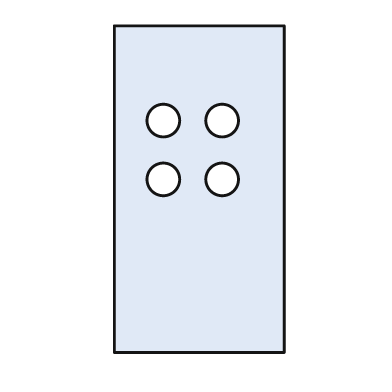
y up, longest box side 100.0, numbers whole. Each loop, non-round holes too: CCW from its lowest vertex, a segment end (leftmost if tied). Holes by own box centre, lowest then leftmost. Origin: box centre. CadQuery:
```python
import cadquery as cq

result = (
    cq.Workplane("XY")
    .moveTo(-26.0, -50.0)
    .lineTo(26.0, -50.0)
    .lineTo(26.0, 50.0)
    .lineTo(-26.0, 50.0)
    .close()
    .moveTo(-11.0, 3.0)
    .circle(5.0)
    .moveTo(7.0, 3.0)
    .circle(5.0)
    .moveTo(-11.0, 21.0)
    .circle(5.0)
    .moveTo(7.0, 21.0)
    .circle(5.0)
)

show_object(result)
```